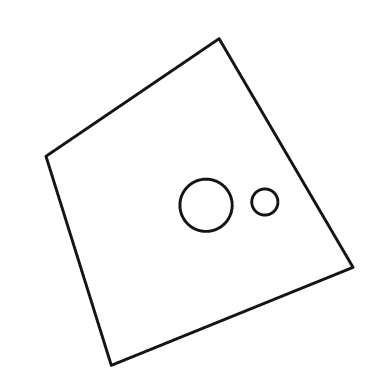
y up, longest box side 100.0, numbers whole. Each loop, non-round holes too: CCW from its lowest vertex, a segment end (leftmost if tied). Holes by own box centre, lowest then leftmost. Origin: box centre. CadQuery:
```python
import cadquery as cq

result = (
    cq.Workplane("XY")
    .moveTo(-27.0, -50.0)
    .lineTo(47.0, -20.0)
    .lineTo(6.0, 50.0)
    .lineTo(-47.0, 14.0)
    .close()
    .moveTo(2.0, -1.0)
    .circle(8.0)
    .moveTo(20.0, 0.0)
    .circle(4.0)
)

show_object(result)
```